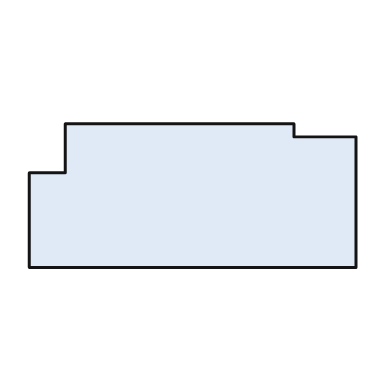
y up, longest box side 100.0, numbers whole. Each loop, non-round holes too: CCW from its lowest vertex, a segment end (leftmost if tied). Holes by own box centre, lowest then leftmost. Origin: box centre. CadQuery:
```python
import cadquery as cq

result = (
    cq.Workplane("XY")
    .moveTo(-50.0, -22.0)
    .lineTo(50.0, -22.0)
    .lineTo(50.0, 18.0)
    .lineTo(31.0, 18.0)
    .lineTo(31.0, 22.0)
    .lineTo(-39.0, 22.0)
    .lineTo(-39.0, 7.0)
    .lineTo(-50.0, 7.0)
    .close()
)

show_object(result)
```